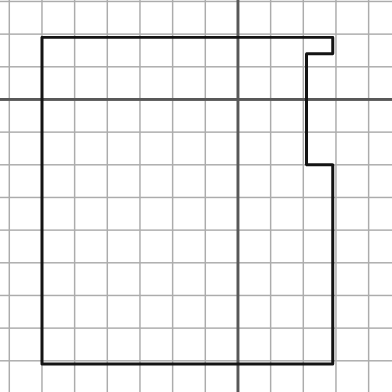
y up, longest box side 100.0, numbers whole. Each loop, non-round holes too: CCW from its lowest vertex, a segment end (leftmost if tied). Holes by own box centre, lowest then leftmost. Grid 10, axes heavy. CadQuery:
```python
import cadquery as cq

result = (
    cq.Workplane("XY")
    .moveTo(-60.0, -81.0)
    .lineTo(29.0, -81.0)
    .lineTo(29.0, -20.0)
    .lineTo(21.0, -20.0)
    .lineTo(21.0, 14.0)
    .lineTo(29.0, 14.0)
    .lineTo(29.0, 19.0)
    .lineTo(-60.0, 19.0)
    .close()
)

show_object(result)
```